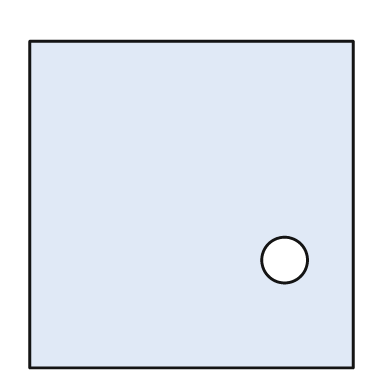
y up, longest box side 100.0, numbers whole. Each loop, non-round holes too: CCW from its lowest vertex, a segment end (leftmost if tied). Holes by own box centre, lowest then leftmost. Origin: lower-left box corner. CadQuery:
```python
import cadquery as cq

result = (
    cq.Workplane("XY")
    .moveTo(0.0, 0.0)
    .lineTo(99.0, 0.0)
    .lineTo(99.0, 100.0)
    .lineTo(0.0, 100.0)
    .close()
    .moveTo(78.0, 33.0)
    .circle(7.0)
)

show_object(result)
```